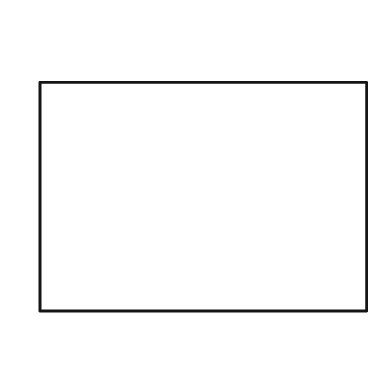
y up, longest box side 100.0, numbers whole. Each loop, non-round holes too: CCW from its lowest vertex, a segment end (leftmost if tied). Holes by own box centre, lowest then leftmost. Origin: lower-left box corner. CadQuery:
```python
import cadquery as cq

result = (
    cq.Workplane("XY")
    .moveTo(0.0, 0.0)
    .lineTo(100.0, 0.0)
    .lineTo(100.0, 70.0)
    .lineTo(0.0, 70.0)
    .close()
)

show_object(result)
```